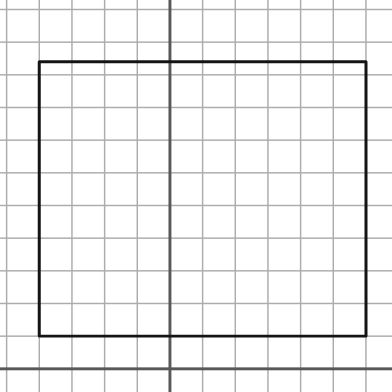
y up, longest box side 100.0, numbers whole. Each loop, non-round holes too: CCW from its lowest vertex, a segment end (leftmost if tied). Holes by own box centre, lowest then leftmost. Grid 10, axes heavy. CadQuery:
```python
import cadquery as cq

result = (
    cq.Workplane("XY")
    .moveTo(-40.0, 10.0)
    .lineTo(60.0, 10.0)
    .lineTo(60.0, 94.0)
    .lineTo(-40.0, 94.0)
    .close()
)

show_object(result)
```